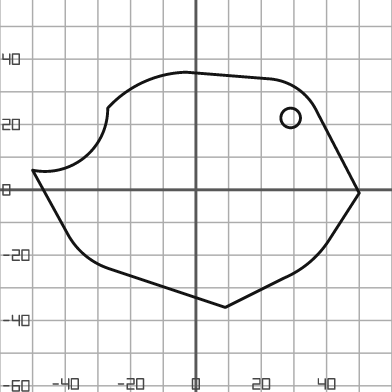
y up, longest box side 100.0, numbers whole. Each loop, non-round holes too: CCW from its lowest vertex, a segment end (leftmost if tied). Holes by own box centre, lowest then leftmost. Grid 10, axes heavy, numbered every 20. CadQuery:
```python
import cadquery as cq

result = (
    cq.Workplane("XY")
    .moveTo(9.0, -36.0)
    .lineTo(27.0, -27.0)
    .threePointArc((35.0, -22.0), (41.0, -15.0))
    .lineTo(50.0, -1.0)
    .lineTo(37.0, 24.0)
    .threePointArc((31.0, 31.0), (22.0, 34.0))
    .lineTo(-3.0, 36.0)
    .threePointArc((-16.0, 33.0), (-27.0, 25.0))
    .threePointArc((-34.0, 10.0), (-50.0, 6.0))
    .lineTo(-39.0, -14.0)
    .threePointArc((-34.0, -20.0), (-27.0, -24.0))
    .close()
    .moveTo(29.0, 22.0)
    .circle(3.0)
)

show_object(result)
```